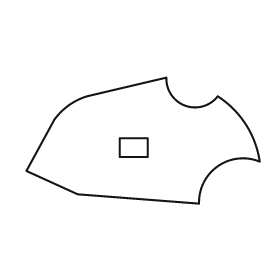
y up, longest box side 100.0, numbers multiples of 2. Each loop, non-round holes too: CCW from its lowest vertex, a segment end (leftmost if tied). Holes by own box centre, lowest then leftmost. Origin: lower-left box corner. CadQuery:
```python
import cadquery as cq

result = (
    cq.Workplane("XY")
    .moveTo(74.0, 0.0)
    .threePointArc((82.0, 16.0), (100.0, 18.0))
    .threePointArc((94.0, 34.0), (82.0, 46.0))
    .threePointArc((68.0, 42.0), (60.0, 54.0))
    .lineTo(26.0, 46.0)
    .threePointArc((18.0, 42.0), (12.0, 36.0))
    .lineTo(0.0, 14.0)
    .lineTo(22.0, 4.0)
    .close()
    .moveTo(40.0, 20.0)
    .lineTo(52.0, 20.0)
    .lineTo(52.0, 28.0)
    .lineTo(40.0, 28.0)
    .close()
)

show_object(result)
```